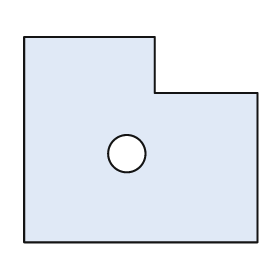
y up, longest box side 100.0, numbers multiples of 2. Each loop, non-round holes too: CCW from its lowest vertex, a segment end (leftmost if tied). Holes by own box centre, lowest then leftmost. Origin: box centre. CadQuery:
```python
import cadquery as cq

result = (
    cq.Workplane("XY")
    .moveTo(-50.0, -44.0)
    .lineTo(50.0, -44.0)
    .lineTo(50.0, 20.0)
    .lineTo(6.0, 20.0)
    .lineTo(6.0, 44.0)
    .lineTo(-50.0, 44.0)
    .close()
    .moveTo(-6.0, -6.0)
    .circle(8.0)
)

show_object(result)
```